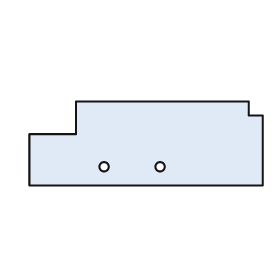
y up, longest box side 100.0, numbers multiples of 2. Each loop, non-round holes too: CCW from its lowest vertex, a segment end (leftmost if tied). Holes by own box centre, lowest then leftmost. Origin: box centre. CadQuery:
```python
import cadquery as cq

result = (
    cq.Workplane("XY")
    .moveTo(-50.0, -18.0)
    .lineTo(50.0, -18.0)
    .lineTo(50.0, 12.0)
    .lineTo(44.0, 12.0)
    .lineTo(44.0, 18.0)
    .lineTo(-30.0, 18.0)
    .lineTo(-30.0, 4.0)
    .lineTo(-50.0, 4.0)
    .close()
    .moveTo(-18.0, -10.0)
    .circle(2.0)
    .moveTo(6.0, -10.0)
    .circle(2.0)
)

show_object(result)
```